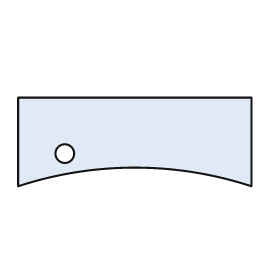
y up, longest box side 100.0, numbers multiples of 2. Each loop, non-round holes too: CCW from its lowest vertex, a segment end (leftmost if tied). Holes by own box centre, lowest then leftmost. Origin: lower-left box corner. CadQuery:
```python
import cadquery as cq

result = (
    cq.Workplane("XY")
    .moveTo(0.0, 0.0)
    .threePointArc((50.0, 8.0), (100.0, 0.0))
    .lineTo(100.0, 38.0)
    .lineTo(0.0, 38.0)
    .close()
    .moveTo(20.0, 14.0)
    .circle(4.0)
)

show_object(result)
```